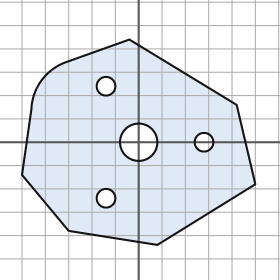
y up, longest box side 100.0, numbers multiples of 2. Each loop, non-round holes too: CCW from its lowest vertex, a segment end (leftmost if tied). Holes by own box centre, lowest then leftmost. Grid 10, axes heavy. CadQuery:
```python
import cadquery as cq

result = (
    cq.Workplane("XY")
    .moveTo(8.0, -44.0)
    .lineTo(50.0, -18.0)
    .lineTo(42.0, 16.0)
    .lineTo(-4.0, 44.0)
    .lineTo(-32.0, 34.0)
    .threePointArc((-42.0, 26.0), (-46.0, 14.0))
    .lineTo(-50.0, -14.0)
    .lineTo(-30.0, -38.0)
    .close()
    .moveTo(-14.0, -24.0)
    .circle(4.0)
    .moveTo(0.0, 0.0)
    .circle(8.0)
    .moveTo(28.0, 0.0)
    .circle(4.0)
    .moveTo(-14.0, 24.0)
    .circle(4.0)
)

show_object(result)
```